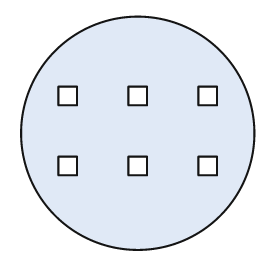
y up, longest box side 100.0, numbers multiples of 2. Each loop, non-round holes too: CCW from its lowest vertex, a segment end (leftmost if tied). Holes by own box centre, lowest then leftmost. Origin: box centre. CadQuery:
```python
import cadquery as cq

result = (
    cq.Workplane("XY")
    .moveTo(0.0, 0.0)
    .circle(50.0)
    .moveTo(-34.0, -18.0)
    .lineTo(-26.0, -18.0)
    .lineTo(-26.0, -10.0)
    .lineTo(-34.0, -10.0)
    .close()
    .moveTo(-4.0, -18.0)
    .lineTo(4.0, -18.0)
    .lineTo(4.0, -10.0)
    .lineTo(-4.0, -10.0)
    .close()
    .moveTo(26.0, -18.0)
    .lineTo(34.0, -18.0)
    .lineTo(34.0, -10.0)
    .lineTo(26.0, -10.0)
    .close()
    .moveTo(-34.0, 12.0)
    .lineTo(-26.0, 12.0)
    .lineTo(-26.0, 20.0)
    .lineTo(-34.0, 20.0)
    .close()
    .moveTo(-4.0, 12.0)
    .lineTo(4.0, 12.0)
    .lineTo(4.0, 20.0)
    .lineTo(-4.0, 20.0)
    .close()
    .moveTo(26.0, 12.0)
    .lineTo(34.0, 12.0)
    .lineTo(34.0, 20.0)
    .lineTo(26.0, 20.0)
    .close()
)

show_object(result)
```